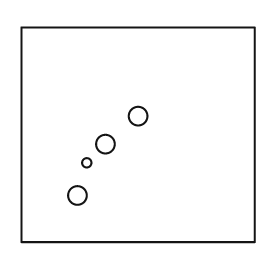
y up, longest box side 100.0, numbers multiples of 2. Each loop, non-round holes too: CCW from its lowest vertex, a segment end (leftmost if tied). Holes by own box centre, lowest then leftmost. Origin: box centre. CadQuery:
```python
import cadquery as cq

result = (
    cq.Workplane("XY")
    .moveTo(-50.0, -46.0)
    .lineTo(50.0, -46.0)
    .lineTo(50.0, 46.0)
    .lineTo(-50.0, 46.0)
    .close()
    .moveTo(-26.0, -26.0)
    .circle(4.0)
    .moveTo(-22.0, -12.0)
    .circle(2.0)
    .moveTo(-14.0, -4.0)
    .circle(4.0)
    .moveTo(0.0, 8.0)
    .circle(4.0)
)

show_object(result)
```